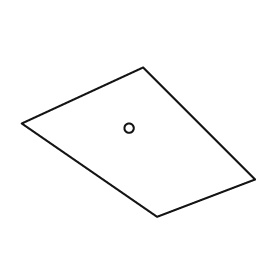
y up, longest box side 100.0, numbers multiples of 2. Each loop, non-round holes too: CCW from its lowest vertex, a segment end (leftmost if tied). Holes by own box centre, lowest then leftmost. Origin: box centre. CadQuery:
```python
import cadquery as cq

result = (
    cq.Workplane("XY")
    .moveTo(8.0, -32.0)
    .lineTo(50.0, -16.0)
    .lineTo(2.0, 32.0)
    .lineTo(-50.0, 8.0)
    .close()
    .moveTo(-4.0, 6.0)
    .circle(2.0)
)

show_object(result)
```